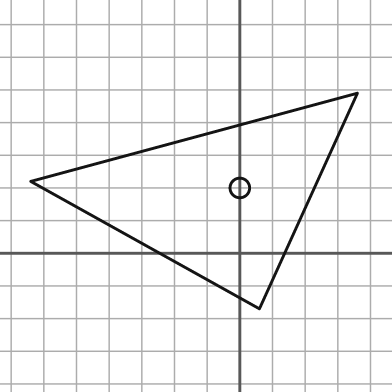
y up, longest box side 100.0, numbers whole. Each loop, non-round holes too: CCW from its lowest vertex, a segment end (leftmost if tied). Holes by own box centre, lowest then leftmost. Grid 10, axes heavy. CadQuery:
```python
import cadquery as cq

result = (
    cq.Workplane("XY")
    .moveTo(6.0, -17.0)
    .lineTo(36.0, 49.0)
    .lineTo(-64.0, 22.0)
    .close()
    .moveTo(0.0, 20.0)
    .circle(3.0)
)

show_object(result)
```